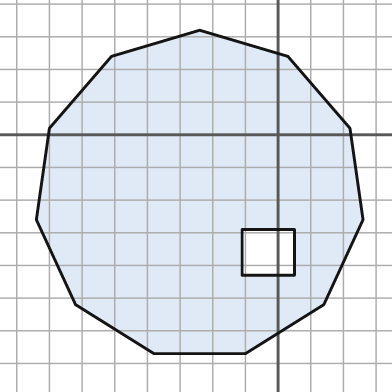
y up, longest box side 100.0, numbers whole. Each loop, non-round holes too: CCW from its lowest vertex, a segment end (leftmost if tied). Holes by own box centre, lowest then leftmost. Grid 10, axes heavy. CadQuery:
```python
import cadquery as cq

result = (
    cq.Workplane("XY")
    .moveTo(-38.0, -67.0)
    .lineTo(-10.0, -67.0)
    .lineTo(14.0, -52.0)
    .lineTo(26.0, -26.0)
    .lineTo(22.0, 2.0)
    .lineTo(3.0, 24.0)
    .lineTo(-24.0, 32.0)
    .lineTo(-51.0, 24.0)
    .lineTo(-70.0, 2.0)
    .lineTo(-74.0, -26.0)
    .lineTo(-62.0, -52.0)
    .close()
    .moveTo(-11.0, -43.0)
    .lineTo(5.0, -43.0)
    .lineTo(5.0, -29.0)
    .lineTo(-11.0, -29.0)
    .close()
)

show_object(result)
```